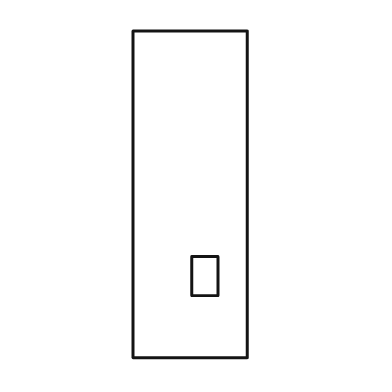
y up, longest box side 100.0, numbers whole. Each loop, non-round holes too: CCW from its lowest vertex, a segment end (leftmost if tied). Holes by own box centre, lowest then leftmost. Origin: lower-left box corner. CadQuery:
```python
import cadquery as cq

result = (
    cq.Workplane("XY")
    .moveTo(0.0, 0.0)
    .lineTo(35.0, 0.0)
    .lineTo(35.0, 100.0)
    .lineTo(0.0, 100.0)
    .close()
    .moveTo(18.0, 19.0)
    .lineTo(26.0, 19.0)
    .lineTo(26.0, 31.0)
    .lineTo(18.0, 31.0)
    .close()
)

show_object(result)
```